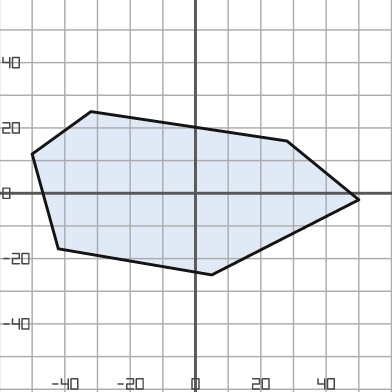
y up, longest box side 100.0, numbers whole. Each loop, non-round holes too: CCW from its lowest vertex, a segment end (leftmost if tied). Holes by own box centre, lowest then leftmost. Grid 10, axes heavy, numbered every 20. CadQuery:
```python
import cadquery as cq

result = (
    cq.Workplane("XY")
    .moveTo(5.0, -25.0)
    .lineTo(50.0, -2.0)
    .lineTo(28.0, 16.0)
    .lineTo(-32.0, 25.0)
    .lineTo(-50.0, 12.0)
    .lineTo(-42.0, -17.0)
    .close()
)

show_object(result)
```